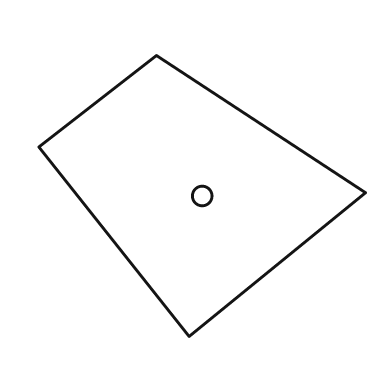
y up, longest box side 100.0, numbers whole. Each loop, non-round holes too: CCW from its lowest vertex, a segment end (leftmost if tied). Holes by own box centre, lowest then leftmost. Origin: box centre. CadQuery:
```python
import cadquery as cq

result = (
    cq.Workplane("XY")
    .moveTo(-4.0, -43.0)
    .lineTo(50.0, 1.0)
    .lineTo(-14.0, 43.0)
    .lineTo(-50.0, 15.0)
    .close()
    .moveTo(0.0, 0.0)
    .circle(3.0)
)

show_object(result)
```